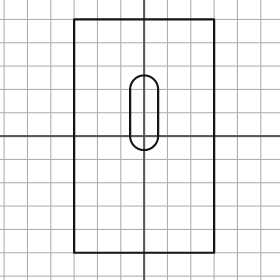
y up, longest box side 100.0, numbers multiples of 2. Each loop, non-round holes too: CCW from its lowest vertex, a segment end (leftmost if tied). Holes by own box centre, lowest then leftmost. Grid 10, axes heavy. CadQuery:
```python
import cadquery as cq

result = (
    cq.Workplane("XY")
    .moveTo(-30.0, -50.0)
    .lineTo(30.0, -50.0)
    .lineTo(30.0, 50.0)
    .lineTo(-30.0, 50.0)
    .close()
    .moveTo(-6.0, 0.0)
    .threePointArc((0.0, -6.0), (6.0, 0.0))
    .lineTo(6.0, 20.0)
    .threePointArc((0.0, 26.0), (-6.0, 20.0))
    .close()
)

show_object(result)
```